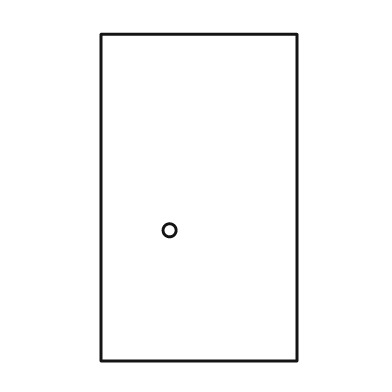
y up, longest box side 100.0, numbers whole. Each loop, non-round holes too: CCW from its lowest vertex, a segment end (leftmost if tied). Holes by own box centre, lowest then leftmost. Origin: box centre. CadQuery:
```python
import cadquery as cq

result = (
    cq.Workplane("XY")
    .moveTo(-30.0, -50.0)
    .lineTo(30.0, -50.0)
    .lineTo(30.0, 50.0)
    .lineTo(-30.0, 50.0)
    .close()
    .moveTo(-9.0, -10.0)
    .circle(2.0)
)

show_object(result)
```